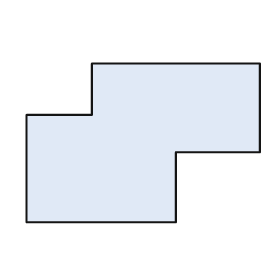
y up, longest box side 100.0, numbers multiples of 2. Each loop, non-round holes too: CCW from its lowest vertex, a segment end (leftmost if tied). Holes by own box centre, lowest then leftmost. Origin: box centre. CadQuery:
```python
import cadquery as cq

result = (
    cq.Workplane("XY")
    .moveTo(-50.0, -34.0)
    .lineTo(14.0, -34.0)
    .lineTo(14.0, -4.0)
    .lineTo(50.0, -4.0)
    .lineTo(50.0, 34.0)
    .lineTo(-22.0, 34.0)
    .lineTo(-22.0, 12.0)
    .lineTo(-50.0, 12.0)
    .close()
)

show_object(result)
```